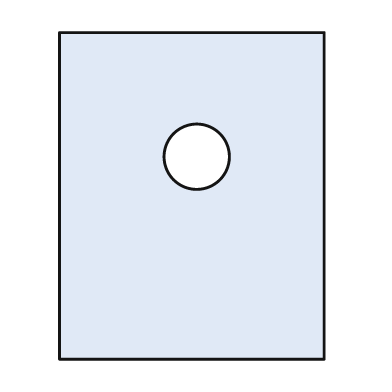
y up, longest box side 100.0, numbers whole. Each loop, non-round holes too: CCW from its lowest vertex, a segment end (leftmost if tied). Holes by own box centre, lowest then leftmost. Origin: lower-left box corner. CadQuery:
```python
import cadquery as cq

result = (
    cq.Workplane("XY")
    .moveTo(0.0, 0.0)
    .lineTo(81.0, 0.0)
    .lineTo(81.0, 100.0)
    .lineTo(0.0, 100.0)
    .close()
    .moveTo(42.0, 62.0)
    .circle(10.0)
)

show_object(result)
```